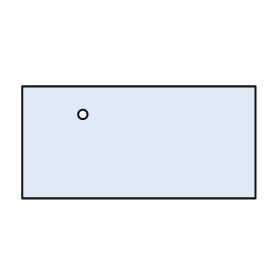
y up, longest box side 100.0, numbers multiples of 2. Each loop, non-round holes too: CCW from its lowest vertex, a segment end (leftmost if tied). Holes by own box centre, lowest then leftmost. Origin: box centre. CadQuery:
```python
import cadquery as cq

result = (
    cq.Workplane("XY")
    .moveTo(-50.0, -24.0)
    .lineTo(50.0, -24.0)
    .lineTo(50.0, 24.0)
    .lineTo(-50.0, 24.0)
    .close()
    .moveTo(-24.0, 12.0)
    .circle(2.0)
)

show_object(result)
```